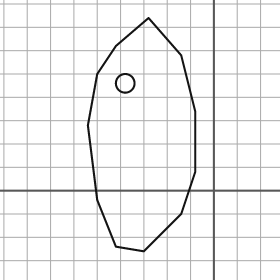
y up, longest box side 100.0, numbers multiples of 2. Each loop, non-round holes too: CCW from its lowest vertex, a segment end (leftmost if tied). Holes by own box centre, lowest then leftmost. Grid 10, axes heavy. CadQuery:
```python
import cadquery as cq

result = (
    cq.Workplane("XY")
    .moveTo(-30.0, -26.0)
    .lineTo(-14.0, -10.0)
    .lineTo(-8.0, 8.0)
    .lineTo(-8.0, 34.0)
    .lineTo(-14.0, 58.0)
    .lineTo(-28.0, 74.0)
    .lineTo(-42.0, 62.0)
    .lineTo(-50.0, 50.0)
    .lineTo(-54.0, 28.0)
    .lineTo(-50.0, -4.0)
    .lineTo(-42.0, -24.0)
    .close()
    .moveTo(-38.0, 46.0)
    .circle(4.0)
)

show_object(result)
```